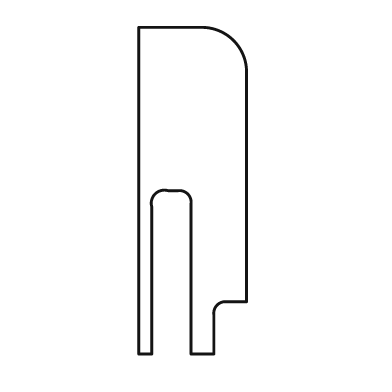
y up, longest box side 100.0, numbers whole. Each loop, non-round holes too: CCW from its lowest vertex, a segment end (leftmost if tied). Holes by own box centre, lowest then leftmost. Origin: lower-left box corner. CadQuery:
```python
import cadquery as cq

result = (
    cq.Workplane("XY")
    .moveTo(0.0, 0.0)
    .lineTo(4.0, 0.0)
    .lineTo(4.0, 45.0)
    .threePointArc((5.0, 49.0), (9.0, 50.0))
    .lineTo(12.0, 50.0)
    .threePointArc((15.0, 49.0), (16.0, 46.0))
    .lineTo(16.0, 0.0)
    .lineTo(23.0, 0.0)
    .lineTo(23.0, 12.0)
    .threePointArc((24.0, 15.0), (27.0, 16.0))
    .lineTo(33.0, 16.0)
    .lineTo(33.0, 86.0)
    .threePointArc((29.0, 96.0), (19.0, 100.0))
    .lineTo(0.0, 100.0)
    .close()
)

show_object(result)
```